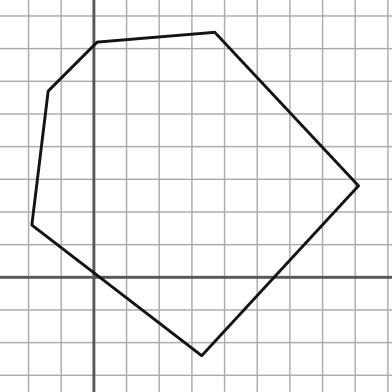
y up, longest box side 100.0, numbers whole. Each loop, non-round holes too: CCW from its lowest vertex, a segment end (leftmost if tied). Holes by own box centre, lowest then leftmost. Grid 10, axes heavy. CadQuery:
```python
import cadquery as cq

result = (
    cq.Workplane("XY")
    .moveTo(33.0, -24.0)
    .lineTo(81.0, 28.0)
    .lineTo(37.0, 75.0)
    .lineTo(1.0, 72.0)
    .lineTo(-14.0, 57.0)
    .lineTo(-19.0, 16.0)
    .close()
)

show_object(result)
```